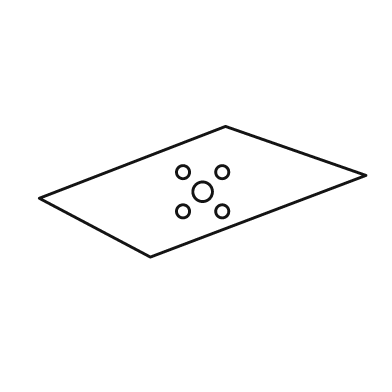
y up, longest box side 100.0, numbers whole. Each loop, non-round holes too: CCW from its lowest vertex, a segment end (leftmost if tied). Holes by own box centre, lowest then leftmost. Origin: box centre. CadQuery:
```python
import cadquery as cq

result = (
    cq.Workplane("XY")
    .moveTo(-16.0, -20.0)
    .lineTo(50.0, 5.0)
    .lineTo(7.0, 20.0)
    .lineTo(-50.0, -2.0)
    .close()
    .moveTo(-6.0, -6.0)
    .circle(2.0)
    .moveTo(6.0, -6.0)
    .circle(2.0)
    .moveTo(0.0, 0.0)
    .circle(3.0)
    .moveTo(-6.0, 6.0)
    .circle(2.0)
    .moveTo(6.0, 6.0)
    .circle(2.0)
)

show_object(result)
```